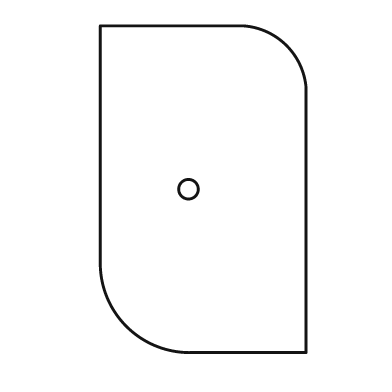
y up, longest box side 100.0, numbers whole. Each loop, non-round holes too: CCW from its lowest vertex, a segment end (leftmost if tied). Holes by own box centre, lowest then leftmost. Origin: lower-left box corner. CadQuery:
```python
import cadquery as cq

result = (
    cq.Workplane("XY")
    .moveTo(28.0, 0.0)
    .lineTo(63.0, 0.0)
    .lineTo(63.0, 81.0)
    .threePointArc((57.0, 94.0), (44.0, 100.0))
    .lineTo(0.0, 100.0)
    .lineTo(0.0, 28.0)
    .threePointArc((8.0, 8.0), (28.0, 0.0))
    .close()
    .moveTo(27.0, 50.0)
    .circle(3.0)
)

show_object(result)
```